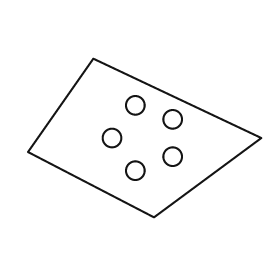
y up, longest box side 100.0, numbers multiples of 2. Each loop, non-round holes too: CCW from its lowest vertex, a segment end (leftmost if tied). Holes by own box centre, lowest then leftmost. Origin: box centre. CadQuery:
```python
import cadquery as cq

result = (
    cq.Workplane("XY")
    .moveTo(4.0, -34.0)
    .lineTo(50.0, 0.0)
    .lineTo(-22.0, 34.0)
    .lineTo(-50.0, -6.0)
    .close()
    .moveTo(-4.0, -14.0)
    .circle(4.0)
    .moveTo(12.0, -8.0)
    .circle(4.0)
    .moveTo(-14.0, 0.0)
    .circle(4.0)
    .moveTo(12.0, 8.0)
    .circle(4.0)
    .moveTo(-4.0, 14.0)
    .circle(4.0)
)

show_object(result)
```